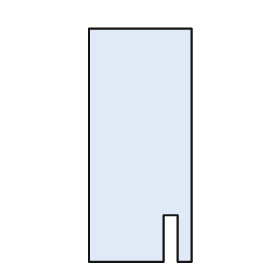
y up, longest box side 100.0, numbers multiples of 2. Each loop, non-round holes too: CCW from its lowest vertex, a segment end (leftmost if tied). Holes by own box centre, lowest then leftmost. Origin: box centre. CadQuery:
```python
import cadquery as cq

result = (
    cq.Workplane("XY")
    .moveTo(-22.0, -50.0)
    .lineTo(10.0, -50.0)
    .lineTo(10.0, -30.0)
    .lineTo(16.0, -30.0)
    .lineTo(16.0, -50.0)
    .lineTo(22.0, -50.0)
    .lineTo(22.0, 50.0)
    .lineTo(-22.0, 50.0)
    .close()
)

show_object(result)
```